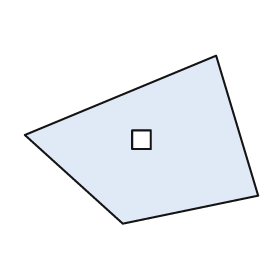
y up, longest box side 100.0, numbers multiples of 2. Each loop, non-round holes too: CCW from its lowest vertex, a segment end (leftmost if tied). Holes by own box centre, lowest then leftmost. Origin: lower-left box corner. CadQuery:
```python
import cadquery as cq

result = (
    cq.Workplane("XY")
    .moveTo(42.0, 0.0)
    .lineTo(100.0, 12.0)
    .lineTo(82.0, 72.0)
    .lineTo(0.0, 38.0)
    .close()
    .moveTo(46.0, 32.0)
    .lineTo(54.0, 32.0)
    .lineTo(54.0, 40.0)
    .lineTo(46.0, 40.0)
    .close()
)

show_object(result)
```